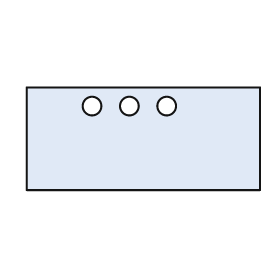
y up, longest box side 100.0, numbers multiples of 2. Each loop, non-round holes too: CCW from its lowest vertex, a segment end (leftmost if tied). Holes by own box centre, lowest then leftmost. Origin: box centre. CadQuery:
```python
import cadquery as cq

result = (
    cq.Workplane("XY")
    .moveTo(-50.0, -22.0)
    .lineTo(50.0, -22.0)
    .lineTo(50.0, 22.0)
    .lineTo(-50.0, 22.0)
    .close()
    .moveTo(-22.0, 14.0)
    .circle(4.0)
    .moveTo(-6.0, 14.0)
    .circle(4.0)
    .moveTo(10.0, 14.0)
    .circle(4.0)
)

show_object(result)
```